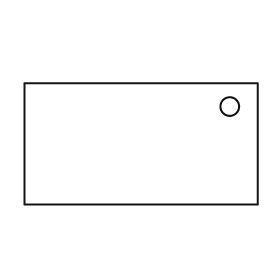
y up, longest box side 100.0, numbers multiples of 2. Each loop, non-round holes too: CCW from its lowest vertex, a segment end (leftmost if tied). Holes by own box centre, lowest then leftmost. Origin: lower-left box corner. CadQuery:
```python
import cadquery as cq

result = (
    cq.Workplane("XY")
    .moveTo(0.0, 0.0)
    .lineTo(100.0, 0.0)
    .lineTo(100.0, 52.0)
    .lineTo(0.0, 52.0)
    .close()
    .moveTo(88.0, 42.0)
    .circle(4.0)
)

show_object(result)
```